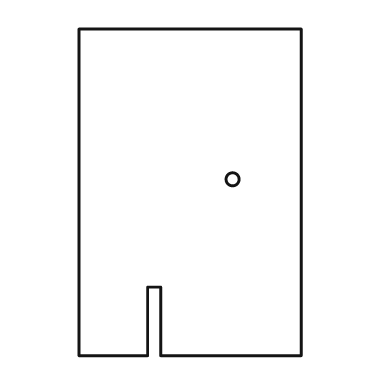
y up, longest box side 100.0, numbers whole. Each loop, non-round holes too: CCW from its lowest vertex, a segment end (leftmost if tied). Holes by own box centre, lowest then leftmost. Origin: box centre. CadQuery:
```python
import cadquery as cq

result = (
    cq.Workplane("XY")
    .moveTo(-34.0, -50.0)
    .lineTo(-13.0, -50.0)
    .lineTo(-13.0, -29.0)
    .lineTo(-9.0, -29.0)
    .lineTo(-9.0, -50.0)
    .lineTo(34.0, -50.0)
    .lineTo(34.0, 50.0)
    .lineTo(-34.0, 50.0)
    .close()
    .moveTo(13.0, 4.0)
    .circle(2.0)
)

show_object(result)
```